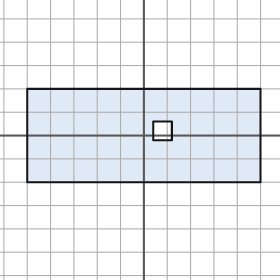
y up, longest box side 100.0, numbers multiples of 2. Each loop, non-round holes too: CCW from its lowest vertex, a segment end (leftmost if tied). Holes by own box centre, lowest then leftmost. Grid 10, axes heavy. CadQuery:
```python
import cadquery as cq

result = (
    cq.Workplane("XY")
    .moveTo(-50.0, -20.0)
    .lineTo(50.0, -20.0)
    .lineTo(50.0, 20.0)
    .lineTo(-50.0, 20.0)
    .close()
    .moveTo(4.0, -2.0)
    .lineTo(12.0, -2.0)
    .lineTo(12.0, 6.0)
    .lineTo(4.0, 6.0)
    .close()
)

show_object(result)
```